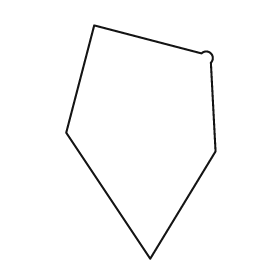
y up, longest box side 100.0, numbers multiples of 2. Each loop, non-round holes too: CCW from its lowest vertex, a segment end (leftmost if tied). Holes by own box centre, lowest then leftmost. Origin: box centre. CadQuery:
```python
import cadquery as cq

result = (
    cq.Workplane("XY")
    .moveTo(4.0, -50.0)
    .lineTo(32.0, -4.0)
    .lineTo(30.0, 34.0)
    .threePointArc((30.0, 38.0), (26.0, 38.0))
    .lineTo(-20.0, 50.0)
    .lineTo(-32.0, 4.0)
    .close()
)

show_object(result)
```